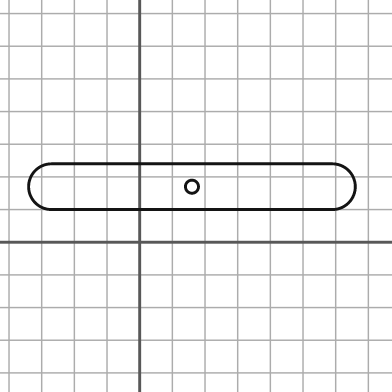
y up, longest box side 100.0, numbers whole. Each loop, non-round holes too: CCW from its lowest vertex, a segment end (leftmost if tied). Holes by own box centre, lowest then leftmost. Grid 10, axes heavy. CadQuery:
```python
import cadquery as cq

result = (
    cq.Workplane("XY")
    .moveTo(-27.0, 10.0)
    .lineTo(59.0, 10.0)
    .threePointArc((66.0, 17.0), (59.0, 24.0))
    .lineTo(-27.0, 24.0)
    .threePointArc((-34.0, 17.0), (-27.0, 10.0))
    .close()
    .moveTo(16.0, 17.0)
    .circle(2.0)
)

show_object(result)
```